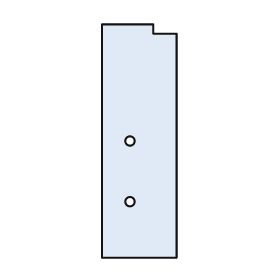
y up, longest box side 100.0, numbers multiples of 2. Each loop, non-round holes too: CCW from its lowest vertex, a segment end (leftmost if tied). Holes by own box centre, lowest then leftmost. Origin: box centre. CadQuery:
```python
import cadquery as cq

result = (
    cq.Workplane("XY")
    .moveTo(-16.0, -50.0)
    .lineTo(16.0, -50.0)
    .lineTo(16.0, 46.0)
    .lineTo(6.0, 46.0)
    .lineTo(6.0, 50.0)
    .lineTo(-16.0, 50.0)
    .close()
    .moveTo(-4.0, -26.0)
    .circle(2.0)
    .moveTo(-4.0, 0.0)
    .circle(2.0)
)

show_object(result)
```